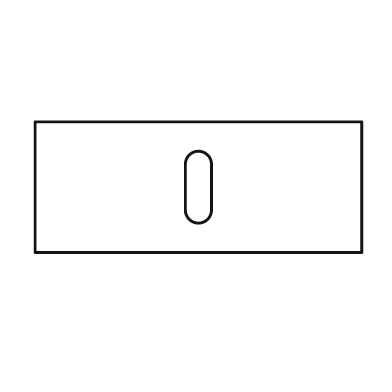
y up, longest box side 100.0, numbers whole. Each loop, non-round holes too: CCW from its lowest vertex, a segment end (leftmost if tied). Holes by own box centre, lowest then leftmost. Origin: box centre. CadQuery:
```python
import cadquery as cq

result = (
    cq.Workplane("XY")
    .moveTo(-50.0, -20.0)
    .lineTo(50.0, -20.0)
    .lineTo(50.0, 20.0)
    .lineTo(-50.0, 20.0)
    .close()
    .moveTo(-4.0, -7.0)
    .threePointArc((0.0, -11.0), (4.0, -7.0))
    .lineTo(4.0, 7.0)
    .threePointArc((0.0, 11.0), (-4.0, 7.0))
    .close()
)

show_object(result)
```